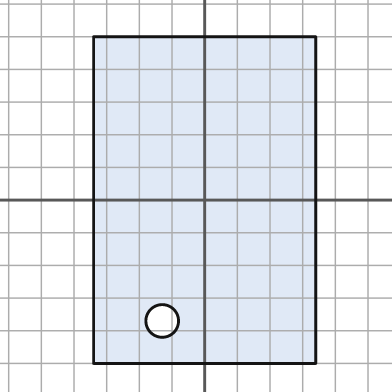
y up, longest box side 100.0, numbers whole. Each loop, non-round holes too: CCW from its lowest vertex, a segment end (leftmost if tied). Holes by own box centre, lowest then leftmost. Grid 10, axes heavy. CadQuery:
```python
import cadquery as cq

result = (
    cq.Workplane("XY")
    .moveTo(-34.0, -50.0)
    .lineTo(34.0, -50.0)
    .lineTo(34.0, 50.0)
    .lineTo(-34.0, 50.0)
    .close()
    .moveTo(-13.0, -37.0)
    .circle(5.0)
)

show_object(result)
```